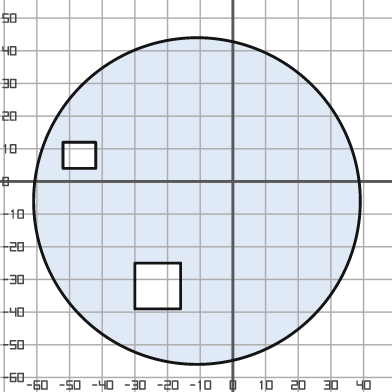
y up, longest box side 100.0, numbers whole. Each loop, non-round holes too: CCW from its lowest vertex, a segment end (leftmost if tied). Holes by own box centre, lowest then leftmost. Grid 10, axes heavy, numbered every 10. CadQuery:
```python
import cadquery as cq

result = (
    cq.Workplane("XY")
    .moveTo(-11.0, -6.0)
    .circle(50.0)
    .moveTo(-30.0, -39.0)
    .lineTo(-16.0, -39.0)
    .lineTo(-16.0, -25.0)
    .lineTo(-30.0, -25.0)
    .close()
    .moveTo(-52.0, 4.0)
    .lineTo(-42.0, 4.0)
    .lineTo(-42.0, 12.0)
    .lineTo(-52.0, 12.0)
    .close()
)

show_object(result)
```